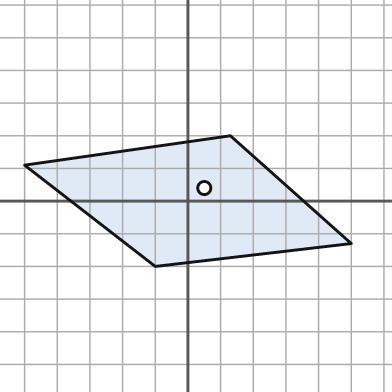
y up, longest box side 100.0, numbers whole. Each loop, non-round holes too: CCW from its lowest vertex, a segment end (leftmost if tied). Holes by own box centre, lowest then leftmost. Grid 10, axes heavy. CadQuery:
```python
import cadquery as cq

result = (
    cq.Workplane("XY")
    .moveTo(-10.0, -20.0)
    .lineTo(50.0, -13.0)
    .lineTo(13.0, 20.0)
    .lineTo(-50.0, 11.0)
    .close()
    .moveTo(5.0, 4.0)
    .circle(2.0)
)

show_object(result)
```